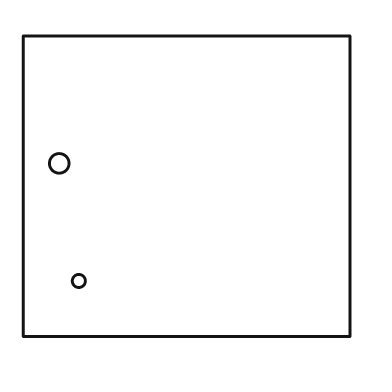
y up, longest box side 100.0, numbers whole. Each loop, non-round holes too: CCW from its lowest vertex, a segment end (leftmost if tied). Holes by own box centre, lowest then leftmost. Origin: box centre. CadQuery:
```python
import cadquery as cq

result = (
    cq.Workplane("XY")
    .moveTo(-50.0, -46.0)
    .lineTo(50.0, -46.0)
    .lineTo(50.0, 46.0)
    .lineTo(-50.0, 46.0)
    .close()
    .moveTo(-33.0, -29.0)
    .circle(2.0)
    .moveTo(-39.0, 7.0)
    .circle(3.0)
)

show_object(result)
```